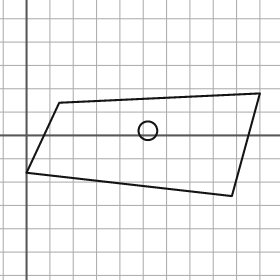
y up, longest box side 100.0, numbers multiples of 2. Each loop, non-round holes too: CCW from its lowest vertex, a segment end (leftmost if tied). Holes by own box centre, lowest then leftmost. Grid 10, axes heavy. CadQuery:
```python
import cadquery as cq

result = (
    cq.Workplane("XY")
    .moveTo(88.0, -26.0)
    .lineTo(100.0, 18.0)
    .lineTo(14.0, 14.0)
    .lineTo(0.0, -16.0)
    .close()
    .moveTo(52.0, 2.0)
    .circle(4.0)
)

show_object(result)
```